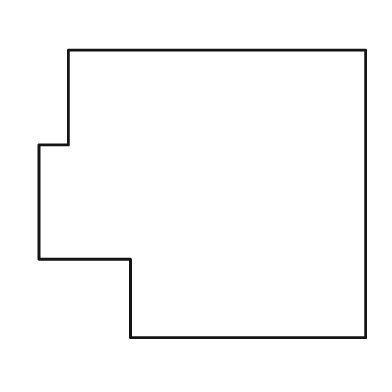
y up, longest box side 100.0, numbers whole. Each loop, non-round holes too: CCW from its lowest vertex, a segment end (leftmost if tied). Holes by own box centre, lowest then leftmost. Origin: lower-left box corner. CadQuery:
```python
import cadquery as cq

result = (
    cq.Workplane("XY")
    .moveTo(28.0, 0.0)
    .lineTo(100.0, 0.0)
    .lineTo(100.0, 88.0)
    .lineTo(9.0, 88.0)
    .lineTo(9.0, 59.0)
    .lineTo(0.0, 59.0)
    .lineTo(0.0, 24.0)
    .lineTo(28.0, 24.0)
    .close()
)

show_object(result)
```